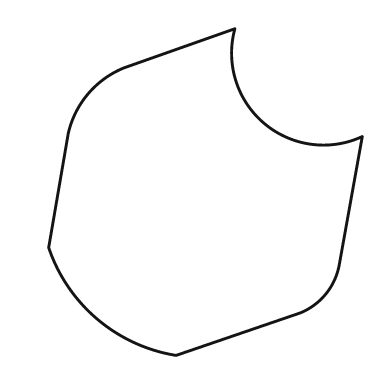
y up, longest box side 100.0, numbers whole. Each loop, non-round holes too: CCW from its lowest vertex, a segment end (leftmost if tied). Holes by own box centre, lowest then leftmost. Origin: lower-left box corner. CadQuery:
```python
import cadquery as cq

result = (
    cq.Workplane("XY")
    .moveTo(39.0, 0.0)
    .lineTo(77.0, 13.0)
    .threePointArc((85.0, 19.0), (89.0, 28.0))
    .lineTo(96.0, 67.0)
    .threePointArc((66.0, 71.0), (57.0, 100.0))
    .lineTo(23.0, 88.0)
    .threePointArc((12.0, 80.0), (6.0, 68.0))
    .lineTo(0.0, 33.0)
    .threePointArc((15.0, 11.0), (39.0, 0.0))
    .close()
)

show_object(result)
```